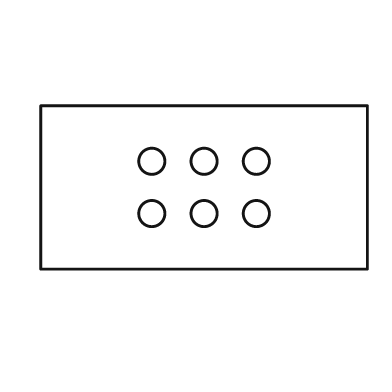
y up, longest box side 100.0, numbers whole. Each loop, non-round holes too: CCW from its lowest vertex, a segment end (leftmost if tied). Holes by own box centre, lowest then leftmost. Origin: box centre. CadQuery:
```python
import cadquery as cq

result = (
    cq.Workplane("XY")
    .moveTo(-50.0, -25.0)
    .lineTo(50.0, -25.0)
    .lineTo(50.0, 25.0)
    .lineTo(-50.0, 25.0)
    .close()
    .moveTo(-16.0, -8.0)
    .circle(4.0)
    .moveTo(0.0, -8.0)
    .circle(4.0)
    .moveTo(16.0, -8.0)
    .circle(4.0)
    .moveTo(-16.0, 8.0)
    .circle(4.0)
    .moveTo(0.0, 8.0)
    .circle(4.0)
    .moveTo(16.0, 8.0)
    .circle(4.0)
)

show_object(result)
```